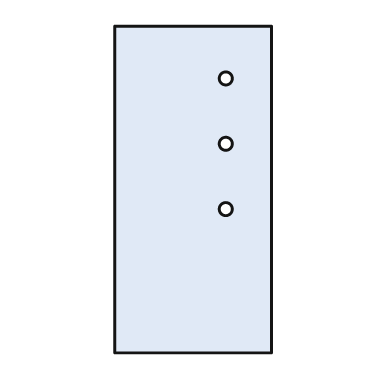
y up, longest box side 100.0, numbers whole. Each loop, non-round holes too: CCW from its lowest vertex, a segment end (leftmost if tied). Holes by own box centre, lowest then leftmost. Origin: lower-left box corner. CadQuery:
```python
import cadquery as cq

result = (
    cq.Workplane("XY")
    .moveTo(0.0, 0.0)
    .lineTo(48.0, 0.0)
    .lineTo(48.0, 100.0)
    .lineTo(0.0, 100.0)
    .close()
    .moveTo(34.0, 44.0)
    .circle(2.0)
    .moveTo(34.0, 64.0)
    .circle(2.0)
    .moveTo(34.0, 84.0)
    .circle(2.0)
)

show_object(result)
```